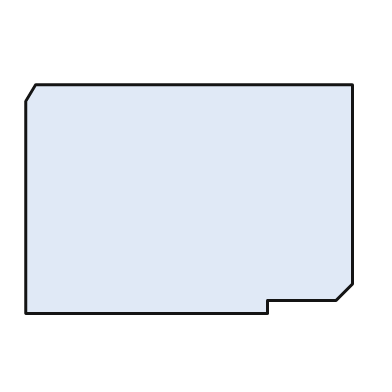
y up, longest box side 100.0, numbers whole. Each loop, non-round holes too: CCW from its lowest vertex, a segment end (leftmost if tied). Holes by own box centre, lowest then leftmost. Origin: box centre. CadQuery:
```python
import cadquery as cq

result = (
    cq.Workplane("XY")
    .moveTo(-50.0, -35.0)
    .lineTo(24.0, -35.0)
    .lineTo(24.0, -31.0)
    .lineTo(45.0, -31.0)
    .lineTo(50.0, -26.0)
    .lineTo(50.0, 35.0)
    .lineTo(-47.0, 35.0)
    .lineTo(-50.0, 30.0)
    .close()
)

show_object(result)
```